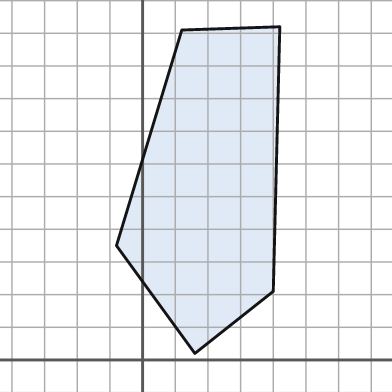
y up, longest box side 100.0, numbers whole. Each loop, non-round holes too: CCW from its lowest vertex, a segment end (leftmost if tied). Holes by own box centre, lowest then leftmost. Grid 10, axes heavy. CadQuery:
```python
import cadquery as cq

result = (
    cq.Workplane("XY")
    .moveTo(16.0, 2.0)
    .lineTo(40.0, 21.0)
    .lineTo(42.0, 102.0)
    .lineTo(12.0, 101.0)
    .lineTo(-8.0, 35.0)
    .close()
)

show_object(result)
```